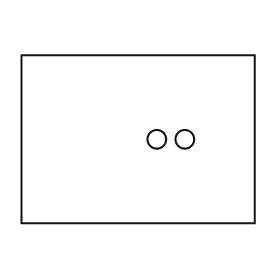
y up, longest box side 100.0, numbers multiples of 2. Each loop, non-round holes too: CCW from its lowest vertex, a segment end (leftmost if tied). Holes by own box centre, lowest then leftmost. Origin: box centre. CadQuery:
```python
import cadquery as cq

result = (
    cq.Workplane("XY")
    .moveTo(-50.0, -36.0)
    .lineTo(50.0, -36.0)
    .lineTo(50.0, 36.0)
    .lineTo(-50.0, 36.0)
    .close()
    .moveTo(8.0, 0.0)
    .circle(4.0)
    .moveTo(20.0, 0.0)
    .circle(4.0)
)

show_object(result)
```